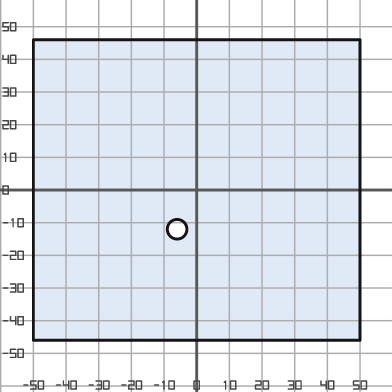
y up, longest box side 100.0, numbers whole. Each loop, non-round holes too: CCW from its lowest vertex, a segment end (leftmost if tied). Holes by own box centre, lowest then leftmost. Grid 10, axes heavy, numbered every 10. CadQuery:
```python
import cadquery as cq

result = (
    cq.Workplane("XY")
    .moveTo(-50.0, -46.0)
    .lineTo(50.0, -46.0)
    .lineTo(50.0, 46.0)
    .lineTo(-50.0, 46.0)
    .close()
    .moveTo(-6.0, -12.0)
    .circle(3.0)
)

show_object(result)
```